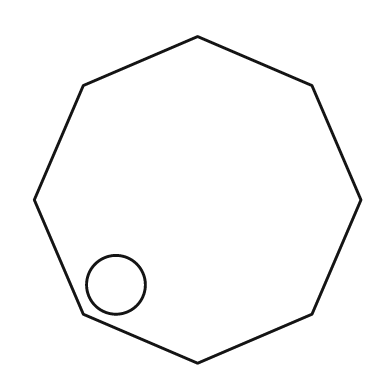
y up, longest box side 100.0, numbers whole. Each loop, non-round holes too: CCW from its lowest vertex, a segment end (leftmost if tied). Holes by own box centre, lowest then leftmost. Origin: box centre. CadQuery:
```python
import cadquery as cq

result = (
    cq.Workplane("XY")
    .moveTo(0.0, -50.0)
    .lineTo(35.0, -35.0)
    .lineTo(50.0, 0.0)
    .lineTo(35.0, 35.0)
    .lineTo(0.0, 50.0)
    .lineTo(-35.0, 35.0)
    .lineTo(-50.0, 0.0)
    .lineTo(-35.0, -35.0)
    .close()
    .moveTo(-25.0, -26.0)
    .circle(9.0)
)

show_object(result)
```